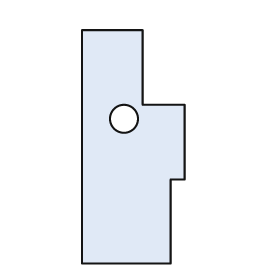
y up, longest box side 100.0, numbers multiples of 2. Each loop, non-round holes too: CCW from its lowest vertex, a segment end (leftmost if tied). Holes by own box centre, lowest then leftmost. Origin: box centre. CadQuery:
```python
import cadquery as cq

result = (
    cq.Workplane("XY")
    .moveTo(-22.0, -50.0)
    .lineTo(16.0, -50.0)
    .lineTo(16.0, -14.0)
    .lineTo(22.0, -14.0)
    .lineTo(22.0, 18.0)
    .lineTo(4.0, 18.0)
    .lineTo(4.0, 50.0)
    .lineTo(-22.0, 50.0)
    .close()
    .moveTo(-4.0, 12.0)
    .circle(6.0)
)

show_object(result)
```